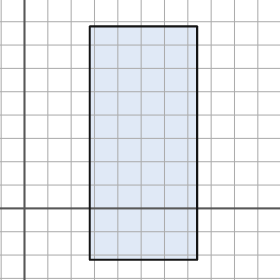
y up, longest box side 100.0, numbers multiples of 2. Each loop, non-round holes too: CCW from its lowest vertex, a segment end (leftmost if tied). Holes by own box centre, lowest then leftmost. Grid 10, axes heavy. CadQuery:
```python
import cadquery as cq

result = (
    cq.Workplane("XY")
    .moveTo(28.0, -22.0)
    .lineTo(74.0, -22.0)
    .lineTo(74.0, 78.0)
    .lineTo(28.0, 78.0)
    .close()
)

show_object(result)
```